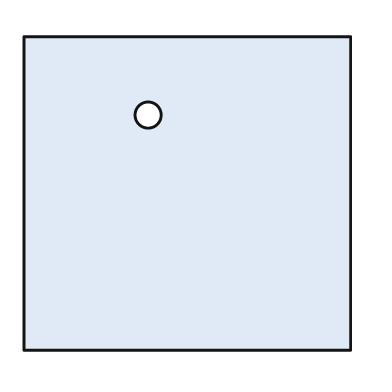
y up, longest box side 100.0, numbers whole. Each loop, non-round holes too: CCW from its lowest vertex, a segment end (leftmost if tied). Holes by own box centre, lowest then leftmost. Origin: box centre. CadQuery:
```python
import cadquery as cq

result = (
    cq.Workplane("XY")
    .moveTo(-50.0, -48.0)
    .lineTo(50.0, -48.0)
    .lineTo(50.0, 48.0)
    .lineTo(-50.0, 48.0)
    .close()
    .moveTo(-12.0, 24.0)
    .circle(4.0)
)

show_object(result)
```